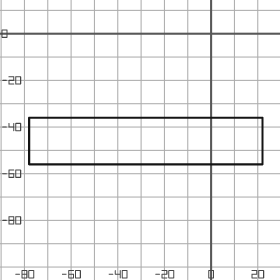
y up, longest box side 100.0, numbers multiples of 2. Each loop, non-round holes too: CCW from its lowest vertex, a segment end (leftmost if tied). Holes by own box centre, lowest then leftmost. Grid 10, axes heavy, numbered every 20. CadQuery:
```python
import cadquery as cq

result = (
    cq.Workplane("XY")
    .moveTo(-78.0, -56.0)
    .lineTo(22.0, -56.0)
    .lineTo(22.0, -36.0)
    .lineTo(-78.0, -36.0)
    .close()
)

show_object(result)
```